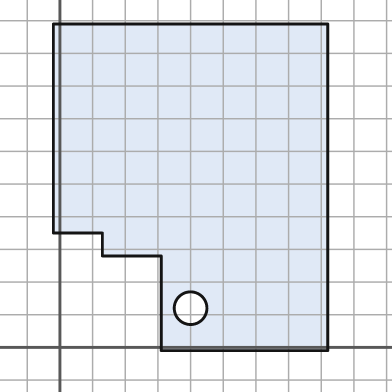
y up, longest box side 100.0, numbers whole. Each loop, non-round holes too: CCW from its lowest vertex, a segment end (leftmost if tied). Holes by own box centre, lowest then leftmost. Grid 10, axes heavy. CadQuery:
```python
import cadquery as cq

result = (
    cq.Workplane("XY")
    .moveTo(31.0, -1.0)
    .lineTo(82.0, -1.0)
    .lineTo(82.0, 99.0)
    .lineTo(-2.0, 99.0)
    .lineTo(-2.0, 35.0)
    .lineTo(13.0, 35.0)
    .lineTo(13.0, 28.0)
    .lineTo(31.0, 28.0)
    .close()
    .moveTo(40.0, 12.0)
    .circle(5.0)
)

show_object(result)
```